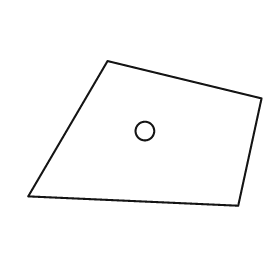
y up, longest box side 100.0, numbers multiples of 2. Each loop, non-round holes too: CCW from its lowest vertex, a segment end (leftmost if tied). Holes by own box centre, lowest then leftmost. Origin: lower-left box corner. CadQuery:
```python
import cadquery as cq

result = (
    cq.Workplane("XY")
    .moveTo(90.0, 0.0)
    .lineTo(100.0, 46.0)
    .lineTo(34.0, 62.0)
    .lineTo(0.0, 4.0)
    .close()
    .moveTo(50.0, 32.0)
    .circle(4.0)
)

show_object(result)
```